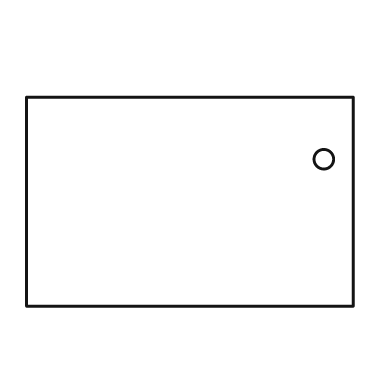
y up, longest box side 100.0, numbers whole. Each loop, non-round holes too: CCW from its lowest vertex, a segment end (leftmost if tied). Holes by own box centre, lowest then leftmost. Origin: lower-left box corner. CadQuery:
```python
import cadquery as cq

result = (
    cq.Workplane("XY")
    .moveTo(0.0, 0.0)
    .lineTo(100.0, 0.0)
    .lineTo(100.0, 64.0)
    .lineTo(0.0, 64.0)
    .close()
    .moveTo(91.0, 45.0)
    .circle(3.0)
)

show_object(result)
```